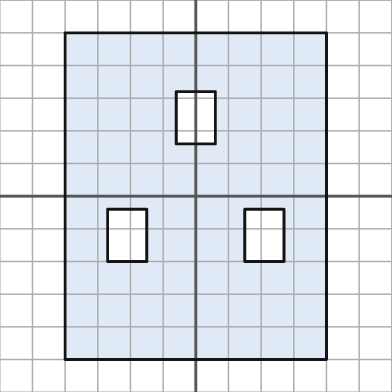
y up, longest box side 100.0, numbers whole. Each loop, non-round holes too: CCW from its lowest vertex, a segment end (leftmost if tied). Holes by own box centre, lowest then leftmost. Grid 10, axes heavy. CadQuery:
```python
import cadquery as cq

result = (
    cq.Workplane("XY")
    .moveTo(-40.0, -50.0)
    .lineTo(40.0, -50.0)
    .lineTo(40.0, 50.0)
    .lineTo(-40.0, 50.0)
    .close()
    .moveTo(-27.0, -20.0)
    .lineTo(-15.0, -20.0)
    .lineTo(-15.0, -4.0)
    .lineTo(-27.0, -4.0)
    .close()
    .moveTo(15.0, -20.0)
    .lineTo(27.0, -20.0)
    .lineTo(27.0, -4.0)
    .lineTo(15.0, -4.0)
    .close()
    .moveTo(-6.0, 16.0)
    .lineTo(6.0, 16.0)
    .lineTo(6.0, 32.0)
    .lineTo(-6.0, 32.0)
    .close()
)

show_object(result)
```